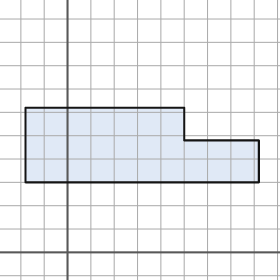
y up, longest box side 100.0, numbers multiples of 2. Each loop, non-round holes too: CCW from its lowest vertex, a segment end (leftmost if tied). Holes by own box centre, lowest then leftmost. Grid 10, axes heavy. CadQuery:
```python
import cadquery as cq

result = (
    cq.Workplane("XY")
    .moveTo(-18.0, 30.0)
    .lineTo(82.0, 30.0)
    .lineTo(82.0, 48.0)
    .lineTo(50.0, 48.0)
    .lineTo(50.0, 62.0)
    .lineTo(-18.0, 62.0)
    .close()
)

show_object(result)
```